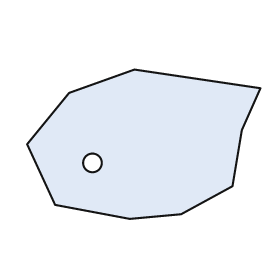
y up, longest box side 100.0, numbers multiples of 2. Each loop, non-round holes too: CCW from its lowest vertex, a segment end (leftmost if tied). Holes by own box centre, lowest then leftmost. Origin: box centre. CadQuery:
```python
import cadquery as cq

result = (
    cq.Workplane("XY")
    .moveTo(-6.0, -32.0)
    .lineTo(16.0, -30.0)
    .lineTo(38.0, -18.0)
    .lineTo(42.0, 6.0)
    .lineTo(50.0, 24.0)
    .lineTo(-4.0, 32.0)
    .lineTo(-32.0, 22.0)
    .lineTo(-50.0, 0.0)
    .lineTo(-38.0, -26.0)
    .close()
    .moveTo(-22.0, -8.0)
    .circle(4.0)
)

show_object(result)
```